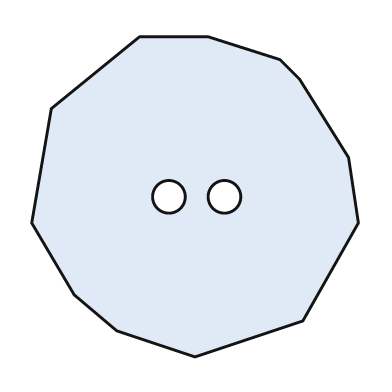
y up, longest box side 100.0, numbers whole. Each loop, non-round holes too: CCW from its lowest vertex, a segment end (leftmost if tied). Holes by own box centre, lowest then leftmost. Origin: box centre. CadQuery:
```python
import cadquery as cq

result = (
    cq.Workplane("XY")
    .moveTo(0.0, -49.0)
    .lineTo(33.0, -38.0)
    .lineTo(50.0, -8.0)
    .lineTo(47.0, 12.0)
    .lineTo(32.0, 36.0)
    .lineTo(26.0, 42.0)
    .lineTo(4.0, 49.0)
    .lineTo(-17.0, 49.0)
    .lineTo(-44.0, 27.0)
    .lineTo(-50.0, -8.0)
    .lineTo(-37.0, -30.0)
    .lineTo(-24.0, -41.0)
    .close()
    .moveTo(-8.0, 0.0)
    .circle(5.0)
    .moveTo(9.0, 0.0)
    .circle(5.0)
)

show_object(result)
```